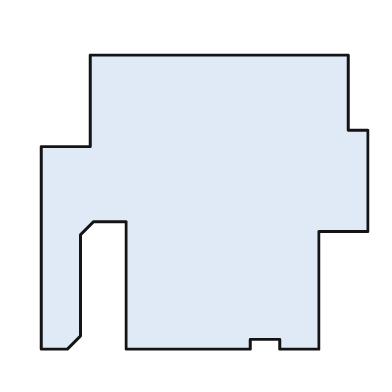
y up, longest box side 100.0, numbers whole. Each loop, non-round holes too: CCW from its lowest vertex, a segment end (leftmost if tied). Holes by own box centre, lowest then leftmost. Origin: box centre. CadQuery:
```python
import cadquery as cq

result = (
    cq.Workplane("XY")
    .moveTo(-50.0, -45.0)
    .lineTo(-42.0, -45.0)
    .lineTo(-38.0, -41.0)
    .lineTo(-38.0, -10.0)
    .lineTo(-34.0, -6.0)
    .lineTo(-24.0, -6.0)
    .lineTo(-24.0, -45.0)
    .lineTo(14.0, -45.0)
    .lineTo(14.0, -42.0)
    .lineTo(23.0, -42.0)
    .lineTo(23.0, -45.0)
    .lineTo(35.0, -45.0)
    .lineTo(35.0, -9.0)
    .lineTo(50.0, -9.0)
    .lineTo(50.0, 22.0)
    .lineTo(44.0, 22.0)
    .lineTo(44.0, 45.0)
    .lineTo(-35.0, 45.0)
    .lineTo(-35.0, 17.0)
    .lineTo(-50.0, 17.0)
    .close()
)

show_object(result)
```